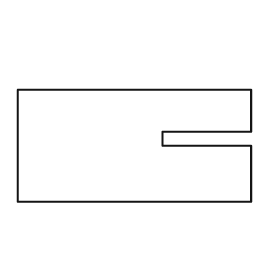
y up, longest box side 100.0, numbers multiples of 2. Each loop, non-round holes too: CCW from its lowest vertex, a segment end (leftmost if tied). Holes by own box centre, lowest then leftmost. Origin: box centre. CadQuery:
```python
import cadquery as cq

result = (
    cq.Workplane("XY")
    .moveTo(-50.0, -24.0)
    .lineTo(50.0, -24.0)
    .lineTo(50.0, 0.0)
    .lineTo(12.0, 0.0)
    .lineTo(12.0, 6.0)
    .lineTo(50.0, 6.0)
    .lineTo(50.0, 24.0)
    .lineTo(-50.0, 24.0)
    .close()
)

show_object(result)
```